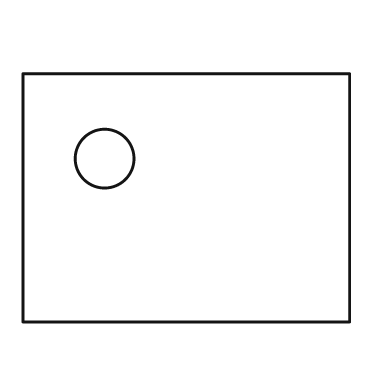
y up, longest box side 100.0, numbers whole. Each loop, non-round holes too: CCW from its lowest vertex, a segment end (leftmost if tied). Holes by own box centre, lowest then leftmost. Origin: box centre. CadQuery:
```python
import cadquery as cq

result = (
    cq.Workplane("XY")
    .moveTo(-50.0, -38.0)
    .lineTo(50.0, -38.0)
    .lineTo(50.0, 38.0)
    .lineTo(-50.0, 38.0)
    .close()
    .moveTo(-25.0, 12.0)
    .circle(9.0)
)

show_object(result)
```